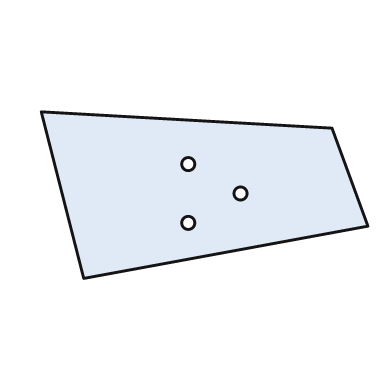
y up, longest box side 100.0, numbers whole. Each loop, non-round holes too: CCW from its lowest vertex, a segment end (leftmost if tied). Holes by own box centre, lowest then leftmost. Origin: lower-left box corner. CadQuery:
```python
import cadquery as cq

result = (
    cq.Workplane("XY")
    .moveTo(13.0, 0.0)
    .lineTo(100.0, 16.0)
    .lineTo(89.0, 46.0)
    .lineTo(0.0, 51.0)
    .close()
    .moveTo(45.0, 17.0)
    .circle(2.0)
    .moveTo(61.0, 26.0)
    .circle(2.0)
    .moveTo(45.0, 35.0)
    .circle(2.0)
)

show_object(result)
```